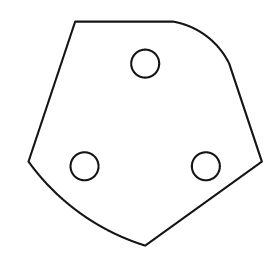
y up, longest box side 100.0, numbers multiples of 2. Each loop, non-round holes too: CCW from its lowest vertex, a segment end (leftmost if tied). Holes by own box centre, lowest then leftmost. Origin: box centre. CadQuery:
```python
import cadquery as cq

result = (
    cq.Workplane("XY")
    .moveTo(0.0, -48.0)
    .lineTo(50.0, -12.0)
    .lineTo(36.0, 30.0)
    .threePointArc((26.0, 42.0), (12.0, 48.0))
    .lineTo(-30.0, 48.0)
    .lineTo(-50.0, -12.0)
    .threePointArc((-28.0, -34.0), (0.0, -48.0))
    .close()
    .moveTo(-26.0, -14.0)
    .circle(6.0)
    .moveTo(26.0, -14.0)
    .circle(6.0)
    .moveTo(0.0, 30.0)
    .circle(6.0)
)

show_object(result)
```